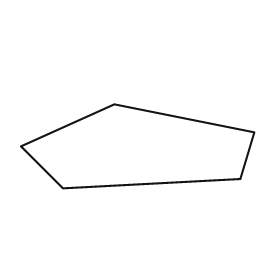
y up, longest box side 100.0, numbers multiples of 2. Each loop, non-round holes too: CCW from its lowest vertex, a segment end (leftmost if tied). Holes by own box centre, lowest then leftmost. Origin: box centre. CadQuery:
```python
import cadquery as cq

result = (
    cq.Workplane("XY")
    .moveTo(-32.0, -18.0)
    .lineTo(44.0, -14.0)
    .lineTo(50.0, 6.0)
    .lineTo(-10.0, 18.0)
    .lineTo(-50.0, 0.0)
    .close()
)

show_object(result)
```